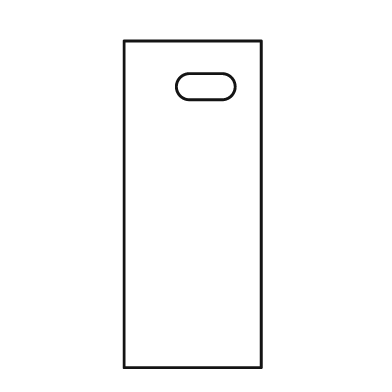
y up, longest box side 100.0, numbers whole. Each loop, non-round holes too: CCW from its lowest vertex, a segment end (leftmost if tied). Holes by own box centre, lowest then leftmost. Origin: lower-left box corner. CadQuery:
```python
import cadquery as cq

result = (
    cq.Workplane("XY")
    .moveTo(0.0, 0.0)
    .lineTo(42.0, 0.0)
    .lineTo(42.0, 100.0)
    .lineTo(0.0, 100.0)
    .close()
    .moveTo(20.0, 82.0)
    .lineTo(30.0, 82.0)
    .threePointArc((34.0, 86.0), (30.0, 90.0))
    .lineTo(20.0, 90.0)
    .threePointArc((16.0, 86.0), (20.0, 82.0))
    .close()
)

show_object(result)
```